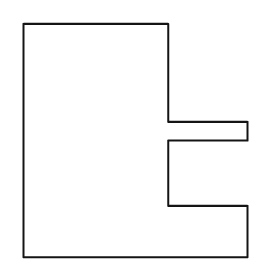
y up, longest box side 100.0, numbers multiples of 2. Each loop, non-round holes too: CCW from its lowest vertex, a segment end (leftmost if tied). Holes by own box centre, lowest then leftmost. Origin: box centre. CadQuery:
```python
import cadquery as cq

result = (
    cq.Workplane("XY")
    .moveTo(-48.0, -50.0)
    .lineTo(48.0, -50.0)
    .lineTo(48.0, -28.0)
    .lineTo(14.0, -28.0)
    .lineTo(14.0, 0.0)
    .lineTo(48.0, 0.0)
    .lineTo(48.0, 8.0)
    .lineTo(14.0, 8.0)
    .lineTo(14.0, 50.0)
    .lineTo(-48.0, 50.0)
    .close()
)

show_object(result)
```